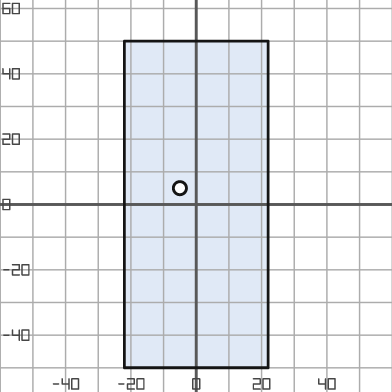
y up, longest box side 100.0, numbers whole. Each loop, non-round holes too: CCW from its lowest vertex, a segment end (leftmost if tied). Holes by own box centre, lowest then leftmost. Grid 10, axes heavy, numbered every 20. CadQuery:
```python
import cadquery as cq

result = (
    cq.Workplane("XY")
    .moveTo(-22.0, -50.0)
    .lineTo(22.0, -50.0)
    .lineTo(22.0, 50.0)
    .lineTo(-22.0, 50.0)
    .close()
    .moveTo(-5.0, 5.0)
    .circle(2.0)
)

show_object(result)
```